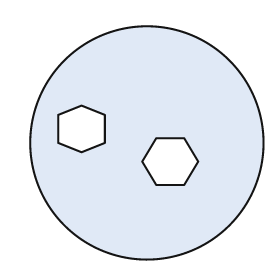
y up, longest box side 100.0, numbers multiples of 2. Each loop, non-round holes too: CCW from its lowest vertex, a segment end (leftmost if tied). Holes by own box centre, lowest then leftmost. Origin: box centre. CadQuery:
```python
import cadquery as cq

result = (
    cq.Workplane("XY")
    .moveTo(0.0, 0.0)
    .circle(50.0)
    .moveTo(4.0, -18.0)
    .lineTo(16.0, -18.0)
    .lineTo(22.0, -8.0)
    .lineTo(16.0, 2.0)
    .lineTo(4.0, 2.0)
    .lineTo(-2.0, -8.0)
    .close()
    .moveTo(-28.0, -4.0)
    .lineTo(-18.0, 0.0)
    .lineTo(-18.0, 12.0)
    .lineTo(-28.0, 16.0)
    .lineTo(-38.0, 12.0)
    .lineTo(-38.0, 0.0)
    .close()
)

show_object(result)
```